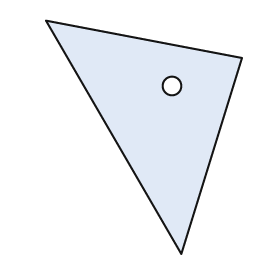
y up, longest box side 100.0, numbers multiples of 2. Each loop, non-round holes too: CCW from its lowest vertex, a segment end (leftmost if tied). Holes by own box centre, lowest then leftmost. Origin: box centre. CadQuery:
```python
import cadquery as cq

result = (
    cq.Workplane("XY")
    .moveTo(16.0, -50.0)
    .lineTo(42.0, 34.0)
    .lineTo(-42.0, 50.0)
    .close()
    .moveTo(12.0, 22.0)
    .circle(4.0)
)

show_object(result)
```